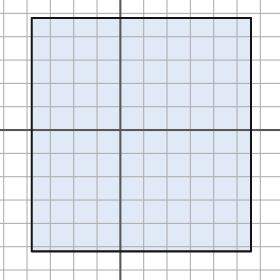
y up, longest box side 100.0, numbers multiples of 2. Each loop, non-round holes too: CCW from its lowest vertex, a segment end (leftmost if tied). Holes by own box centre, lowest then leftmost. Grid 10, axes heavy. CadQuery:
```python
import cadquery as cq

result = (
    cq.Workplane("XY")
    .moveTo(-38.0, -52.0)
    .lineTo(56.0, -52.0)
    .lineTo(56.0, 48.0)
    .lineTo(-38.0, 48.0)
    .close()
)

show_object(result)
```